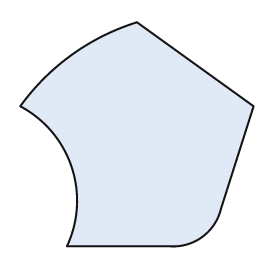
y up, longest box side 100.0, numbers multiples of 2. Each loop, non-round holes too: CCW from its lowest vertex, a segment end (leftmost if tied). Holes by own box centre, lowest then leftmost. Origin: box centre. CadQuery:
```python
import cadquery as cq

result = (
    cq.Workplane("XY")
    .moveTo(-30.0, -48.0)
    .lineTo(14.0, -48.0)
    .threePointArc((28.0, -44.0), (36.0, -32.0))
    .lineTo(50.0, 12.0)
    .lineTo(0.0, 48.0)
    .threePointArc((-28.0, 34.0), (-50.0, 12.0))
    .threePointArc((-28.0, -14.0), (-30.0, -48.0))
    .close()
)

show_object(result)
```